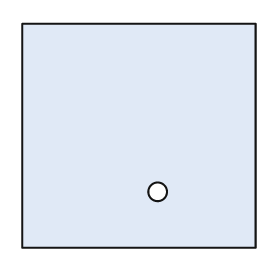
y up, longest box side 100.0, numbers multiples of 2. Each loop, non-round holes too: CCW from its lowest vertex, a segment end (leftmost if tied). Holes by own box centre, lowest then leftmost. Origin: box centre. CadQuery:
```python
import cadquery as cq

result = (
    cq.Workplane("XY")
    .moveTo(-50.0, -48.0)
    .lineTo(50.0, -48.0)
    .lineTo(50.0, 48.0)
    .lineTo(-50.0, 48.0)
    .close()
    .moveTo(8.0, -24.0)
    .circle(4.0)
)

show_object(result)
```